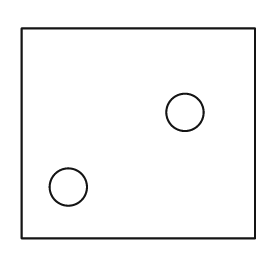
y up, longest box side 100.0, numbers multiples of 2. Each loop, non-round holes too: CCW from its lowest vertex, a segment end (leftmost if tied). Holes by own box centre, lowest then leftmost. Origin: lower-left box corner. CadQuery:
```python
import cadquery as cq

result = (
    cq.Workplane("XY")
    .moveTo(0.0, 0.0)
    .lineTo(100.0, 0.0)
    .lineTo(100.0, 90.0)
    .lineTo(0.0, 90.0)
    .close()
    .moveTo(20.0, 22.0)
    .circle(8.0)
    .moveTo(70.0, 54.0)
    .circle(8.0)
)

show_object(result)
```